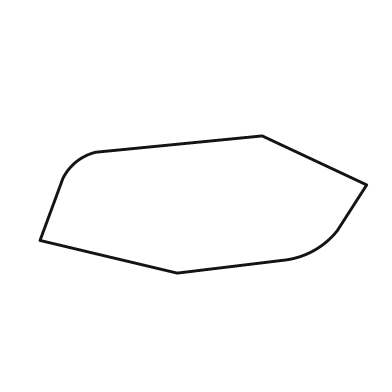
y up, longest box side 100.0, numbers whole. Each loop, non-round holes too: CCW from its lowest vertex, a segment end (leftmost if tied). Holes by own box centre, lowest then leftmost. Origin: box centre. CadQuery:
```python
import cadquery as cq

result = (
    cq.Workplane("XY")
    .moveTo(-8.0, -21.0)
    .lineTo(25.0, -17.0)
    .threePointArc((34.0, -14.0), (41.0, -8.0))
    .lineTo(50.0, 6.0)
    .lineTo(18.0, 21.0)
    .lineTo(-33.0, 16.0)
    .threePointArc((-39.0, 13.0), (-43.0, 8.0))
    .lineTo(-50.0, -11.0)
    .close()
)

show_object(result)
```